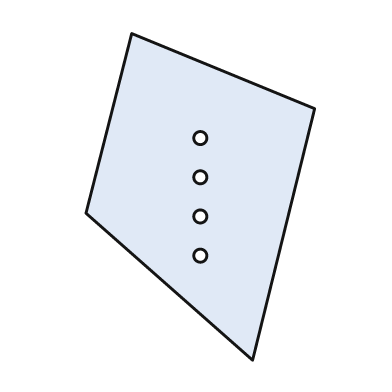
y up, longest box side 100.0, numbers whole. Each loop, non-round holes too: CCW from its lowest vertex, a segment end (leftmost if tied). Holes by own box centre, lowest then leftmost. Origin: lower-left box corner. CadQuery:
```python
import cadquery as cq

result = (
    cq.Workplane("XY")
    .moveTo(51.0, 0.0)
    .lineTo(70.0, 77.0)
    .lineTo(14.0, 100.0)
    .lineTo(0.0, 45.0)
    .close()
    .moveTo(35.0, 32.0)
    .circle(2.0)
    .moveTo(35.0, 44.0)
    .circle(2.0)
    .moveTo(35.0, 56.0)
    .circle(2.0)
    .moveTo(35.0, 68.0)
    .circle(2.0)
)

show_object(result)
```